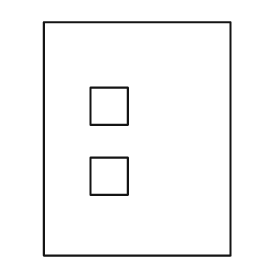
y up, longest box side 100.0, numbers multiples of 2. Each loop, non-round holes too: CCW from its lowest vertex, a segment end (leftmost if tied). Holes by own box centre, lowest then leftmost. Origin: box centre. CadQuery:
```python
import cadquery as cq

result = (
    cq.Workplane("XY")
    .moveTo(-40.0, -50.0)
    .lineTo(40.0, -50.0)
    .lineTo(40.0, 50.0)
    .lineTo(-40.0, 50.0)
    .close()
    .moveTo(-20.0, -24.0)
    .lineTo(-4.0, -24.0)
    .lineTo(-4.0, -8.0)
    .lineTo(-20.0, -8.0)
    .close()
    .moveTo(-20.0, 6.0)
    .lineTo(-4.0, 6.0)
    .lineTo(-4.0, 22.0)
    .lineTo(-20.0, 22.0)
    .close()
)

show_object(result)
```